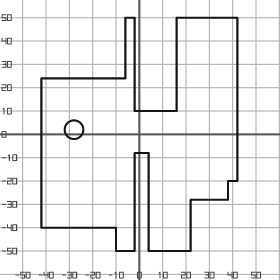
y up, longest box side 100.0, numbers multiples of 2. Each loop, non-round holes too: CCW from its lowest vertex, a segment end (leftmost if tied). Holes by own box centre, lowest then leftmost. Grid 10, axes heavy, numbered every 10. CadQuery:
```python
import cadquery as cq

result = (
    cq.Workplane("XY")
    .moveTo(-10.0, -50.0)
    .lineTo(-2.0, -50.0)
    .lineTo(-2.0, -8.0)
    .lineTo(4.0, -8.0)
    .lineTo(4.0, -50.0)
    .lineTo(22.0, -50.0)
    .lineTo(22.0, -28.0)
    .lineTo(38.0, -28.0)
    .lineTo(38.0, -20.0)
    .lineTo(42.0, -20.0)
    .lineTo(42.0, 50.0)
    .lineTo(16.0, 50.0)
    .lineTo(16.0, 10.0)
    .lineTo(-2.0, 10.0)
    .lineTo(-2.0, 50.0)
    .lineTo(-6.0, 50.0)
    .lineTo(-6.0, 24.0)
    .lineTo(-42.0, 24.0)
    .lineTo(-42.0, -40.0)
    .lineTo(-10.0, -40.0)
    .close()
    .moveTo(-28.0, 2.0)
    .circle(4.0)
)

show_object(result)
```